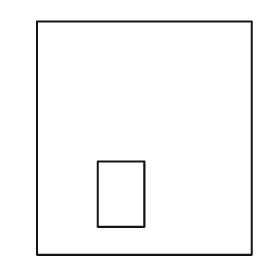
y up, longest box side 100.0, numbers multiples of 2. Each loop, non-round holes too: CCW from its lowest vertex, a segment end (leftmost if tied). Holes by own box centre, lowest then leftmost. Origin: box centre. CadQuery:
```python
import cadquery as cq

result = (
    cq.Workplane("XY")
    .moveTo(-46.0, -50.0)
    .lineTo(46.0, -50.0)
    .lineTo(46.0, 50.0)
    .lineTo(-46.0, 50.0)
    .close()
    .moveTo(-20.0, -38.0)
    .lineTo(0.0, -38.0)
    .lineTo(0.0, -10.0)
    .lineTo(-20.0, -10.0)
    .close()
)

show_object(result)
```